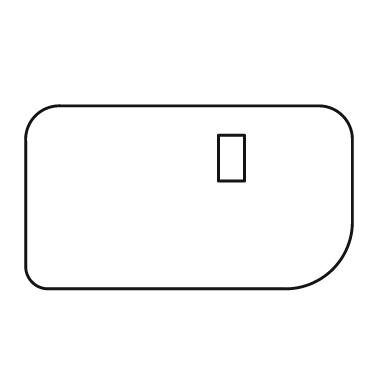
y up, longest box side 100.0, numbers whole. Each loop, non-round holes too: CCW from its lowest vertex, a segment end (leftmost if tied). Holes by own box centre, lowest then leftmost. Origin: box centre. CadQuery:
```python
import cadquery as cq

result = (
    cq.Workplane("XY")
    .moveTo(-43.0, -28.0)
    .lineTo(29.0, -28.0)
    .threePointArc((44.0, -22.0), (50.0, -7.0))
    .lineTo(50.0, 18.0)
    .threePointArc((47.0, 25.0), (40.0, 28.0))
    .lineTo(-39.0, 28.0)
    .threePointArc((-47.0, 25.0), (-50.0, 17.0))
    .lineTo(-50.0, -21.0)
    .threePointArc((-48.0, -26.0), (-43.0, -28.0))
    .close()
    .moveTo(9.0, 5.0)
    .lineTo(17.0, 5.0)
    .lineTo(17.0, 19.0)
    .lineTo(9.0, 19.0)
    .close()
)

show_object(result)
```